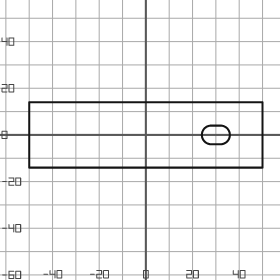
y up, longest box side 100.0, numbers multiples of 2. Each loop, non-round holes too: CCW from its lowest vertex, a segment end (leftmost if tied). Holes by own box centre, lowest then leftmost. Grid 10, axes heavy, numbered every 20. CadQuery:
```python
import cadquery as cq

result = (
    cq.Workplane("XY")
    .moveTo(-50.0, -14.0)
    .lineTo(50.0, -14.0)
    .lineTo(50.0, 14.0)
    .lineTo(-50.0, 14.0)
    .close()
    .moveTo(28.0, -4.0)
    .lineTo(32.0, -4.0)
    .threePointArc((36.0, 0.0), (32.0, 4.0))
    .lineTo(28.0, 4.0)
    .threePointArc((24.0, 0.0), (28.0, -4.0))
    .close()
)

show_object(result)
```